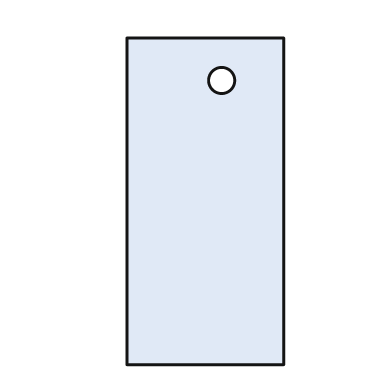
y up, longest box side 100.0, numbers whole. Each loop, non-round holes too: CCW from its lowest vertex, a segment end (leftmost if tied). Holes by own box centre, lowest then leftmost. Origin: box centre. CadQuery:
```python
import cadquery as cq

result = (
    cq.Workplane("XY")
    .moveTo(-24.0, -50.0)
    .lineTo(24.0, -50.0)
    .lineTo(24.0, 50.0)
    .lineTo(-24.0, 50.0)
    .close()
    .moveTo(5.0, 37.0)
    .circle(4.0)
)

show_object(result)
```